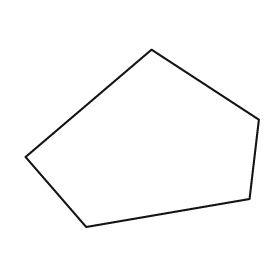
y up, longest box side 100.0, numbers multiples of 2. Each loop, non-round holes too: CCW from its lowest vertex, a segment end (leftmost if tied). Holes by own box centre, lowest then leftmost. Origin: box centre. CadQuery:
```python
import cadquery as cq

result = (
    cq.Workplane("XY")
    .moveTo(-24.0, -38.0)
    .lineTo(46.0, -26.0)
    .lineTo(50.0, 8.0)
    .lineTo(4.0, 38.0)
    .lineTo(-50.0, -8.0)
    .close()
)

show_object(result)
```